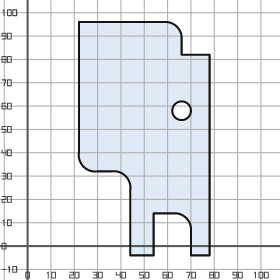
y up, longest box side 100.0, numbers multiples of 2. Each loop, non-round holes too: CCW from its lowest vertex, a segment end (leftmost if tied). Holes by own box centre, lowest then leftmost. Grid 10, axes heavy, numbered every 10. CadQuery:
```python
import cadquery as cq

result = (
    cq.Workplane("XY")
    .moveTo(44.0, -4.0)
    .lineTo(54.0, -4.0)
    .lineTo(54.0, 14.0)
    .lineTo(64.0, 14.0)
    .threePointArc((68.0, 12.0), (70.0, 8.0))
    .lineTo(70.0, -4.0)
    .lineTo(78.0, -4.0)
    .lineTo(78.0, 82.0)
    .lineTo(66.0, 82.0)
    .lineTo(66.0, 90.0)
    .threePointArc((64.0, 94.0), (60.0, 96.0))
    .lineTo(22.0, 96.0)
    .lineTo(22.0, 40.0)
    .threePointArc((24.0, 34.0), (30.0, 32.0))
    .lineTo(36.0, 32.0)
    .threePointArc((42.0, 30.0), (44.0, 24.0))
    .close()
    .moveTo(66.0, 58.0)
    .circle(4.0)
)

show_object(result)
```